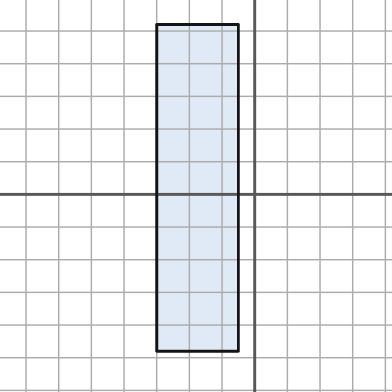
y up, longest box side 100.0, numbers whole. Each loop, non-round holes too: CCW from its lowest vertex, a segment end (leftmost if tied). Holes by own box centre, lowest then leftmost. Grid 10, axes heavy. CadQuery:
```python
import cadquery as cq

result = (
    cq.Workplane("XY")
    .moveTo(-30.0, -48.0)
    .lineTo(-5.0, -48.0)
    .lineTo(-5.0, 52.0)
    .lineTo(-30.0, 52.0)
    .close()
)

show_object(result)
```